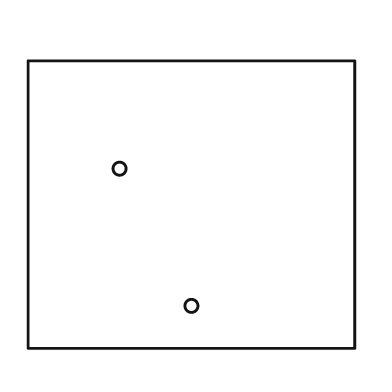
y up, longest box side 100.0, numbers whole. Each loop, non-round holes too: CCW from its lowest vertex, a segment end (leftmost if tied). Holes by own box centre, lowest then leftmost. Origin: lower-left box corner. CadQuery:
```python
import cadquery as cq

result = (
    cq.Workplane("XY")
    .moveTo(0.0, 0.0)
    .lineTo(100.0, 0.0)
    .lineTo(100.0, 88.0)
    .lineTo(0.0, 88.0)
    .close()
    .moveTo(50.0, 13.0)
    .circle(2.0)
    .moveTo(28.0, 55.0)
    .circle(2.0)
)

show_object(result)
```